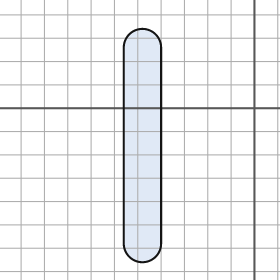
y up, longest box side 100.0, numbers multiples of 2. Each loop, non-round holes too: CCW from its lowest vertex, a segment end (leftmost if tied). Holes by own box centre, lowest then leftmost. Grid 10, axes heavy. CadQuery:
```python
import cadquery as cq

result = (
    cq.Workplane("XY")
    .moveTo(-56.0, -58.0)
    .threePointArc((-48.0, -66.0), (-40.0, -58.0))
    .lineTo(-40.0, 26.0)
    .threePointArc((-48.0, 34.0), (-56.0, 26.0))
    .close()
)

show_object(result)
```